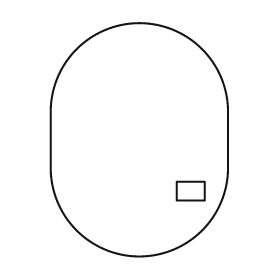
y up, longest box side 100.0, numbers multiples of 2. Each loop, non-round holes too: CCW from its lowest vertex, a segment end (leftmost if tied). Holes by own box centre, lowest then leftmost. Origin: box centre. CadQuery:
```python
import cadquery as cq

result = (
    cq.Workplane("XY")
    .moveTo(-38.0, -12.0)
    .threePointArc((0.0, -50.0), (38.0, -12.0))
    .lineTo(38.0, 12.0)
    .threePointArc((0.0, 50.0), (-38.0, 12.0))
    .close()
    .moveTo(16.0, -26.0)
    .lineTo(28.0, -26.0)
    .lineTo(28.0, -18.0)
    .lineTo(16.0, -18.0)
    .close()
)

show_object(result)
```